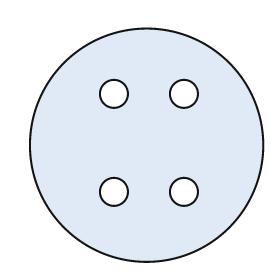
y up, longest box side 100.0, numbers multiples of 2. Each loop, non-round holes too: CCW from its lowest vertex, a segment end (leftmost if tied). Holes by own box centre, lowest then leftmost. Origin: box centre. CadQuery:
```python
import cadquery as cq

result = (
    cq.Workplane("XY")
    .moveTo(0.0, 0.0)
    .circle(50.0)
    .moveTo(-14.0, -20.0)
    .circle(6.0)
    .moveTo(16.0, -20.0)
    .circle(6.0)
    .moveTo(-14.0, 22.0)
    .circle(6.0)
    .moveTo(16.0, 22.0)
    .circle(6.0)
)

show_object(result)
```